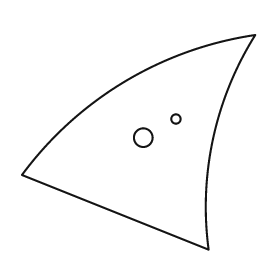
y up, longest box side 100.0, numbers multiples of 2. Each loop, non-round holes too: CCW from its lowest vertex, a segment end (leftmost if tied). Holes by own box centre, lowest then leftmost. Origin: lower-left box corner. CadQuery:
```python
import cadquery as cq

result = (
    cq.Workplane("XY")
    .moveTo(80.0, 0.0)
    .threePointArc((82.0, 48.0), (100.0, 92.0))
    .threePointArc((44.0, 72.0), (0.0, 32.0))
    .close()
    .moveTo(52.0, 48.0)
    .circle(4.0)
    .moveTo(66.0, 56.0)
    .circle(2.0)
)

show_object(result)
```